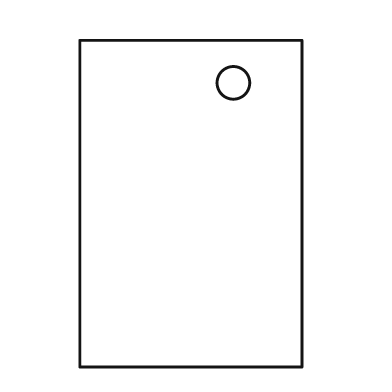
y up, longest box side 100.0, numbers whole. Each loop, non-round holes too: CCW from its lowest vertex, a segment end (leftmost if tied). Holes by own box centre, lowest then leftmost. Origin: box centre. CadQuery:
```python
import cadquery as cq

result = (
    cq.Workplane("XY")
    .moveTo(-34.0, -50.0)
    .lineTo(34.0, -50.0)
    .lineTo(34.0, 50.0)
    .lineTo(-34.0, 50.0)
    .close()
    .moveTo(13.0, 37.0)
    .circle(5.0)
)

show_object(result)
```